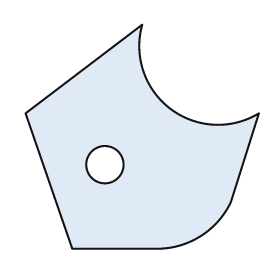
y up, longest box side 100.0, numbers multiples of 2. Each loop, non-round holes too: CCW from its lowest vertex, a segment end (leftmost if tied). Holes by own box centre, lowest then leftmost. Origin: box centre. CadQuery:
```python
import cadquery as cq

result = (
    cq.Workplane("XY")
    .moveTo(-30.0, -48.0)
    .lineTo(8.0, -48.0)
    .threePointArc((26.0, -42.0), (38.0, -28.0))
    .lineTo(50.0, 10.0)
    .threePointArc((12.0, 12.0), (0.0, 48.0))
    .lineTo(-50.0, 10.0)
    .close()
    .moveTo(-16.0, -12.0)
    .circle(8.0)
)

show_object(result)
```